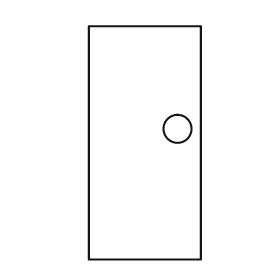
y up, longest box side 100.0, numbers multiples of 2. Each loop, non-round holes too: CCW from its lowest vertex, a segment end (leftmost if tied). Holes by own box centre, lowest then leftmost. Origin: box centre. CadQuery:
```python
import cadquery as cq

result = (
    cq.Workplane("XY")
    .moveTo(-24.0, -50.0)
    .lineTo(24.0, -50.0)
    .lineTo(24.0, 50.0)
    .lineTo(-24.0, 50.0)
    .close()
    .moveTo(14.0, 6.0)
    .circle(6.0)
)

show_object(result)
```